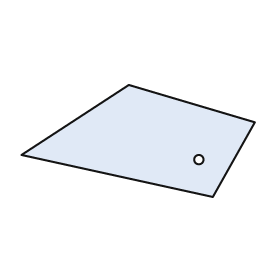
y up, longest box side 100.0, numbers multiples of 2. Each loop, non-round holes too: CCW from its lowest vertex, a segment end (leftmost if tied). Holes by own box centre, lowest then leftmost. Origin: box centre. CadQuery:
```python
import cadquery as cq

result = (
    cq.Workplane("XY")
    .moveTo(32.0, -24.0)
    .lineTo(50.0, 8.0)
    .lineTo(-4.0, 24.0)
    .lineTo(-50.0, -6.0)
    .close()
    .moveTo(26.0, -8.0)
    .circle(2.0)
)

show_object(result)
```